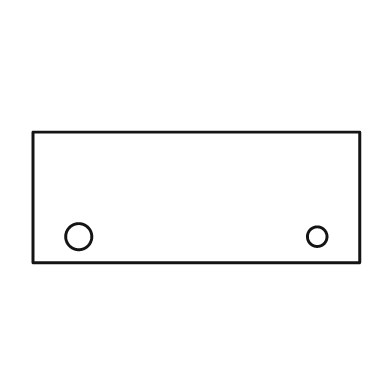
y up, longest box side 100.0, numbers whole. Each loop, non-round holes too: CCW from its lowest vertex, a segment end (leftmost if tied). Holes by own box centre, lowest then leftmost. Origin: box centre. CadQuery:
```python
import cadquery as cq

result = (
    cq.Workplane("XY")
    .moveTo(-50.0, -20.0)
    .lineTo(50.0, -20.0)
    .lineTo(50.0, 20.0)
    .lineTo(-50.0, 20.0)
    .close()
    .moveTo(-36.0, -12.0)
    .circle(4.0)
    .moveTo(37.0, -12.0)
    .circle(3.0)
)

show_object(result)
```